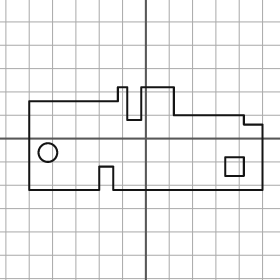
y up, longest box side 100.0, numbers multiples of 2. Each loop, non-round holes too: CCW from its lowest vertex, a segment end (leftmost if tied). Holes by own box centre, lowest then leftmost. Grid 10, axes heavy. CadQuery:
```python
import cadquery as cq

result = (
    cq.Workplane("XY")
    .moveTo(-50.0, -22.0)
    .lineTo(-20.0, -22.0)
    .lineTo(-20.0, -12.0)
    .lineTo(-14.0, -12.0)
    .lineTo(-14.0, -22.0)
    .lineTo(50.0, -22.0)
    .lineTo(50.0, 6.0)
    .lineTo(42.0, 6.0)
    .lineTo(42.0, 10.0)
    .lineTo(12.0, 10.0)
    .lineTo(12.0, 22.0)
    .lineTo(-2.0, 22.0)
    .lineTo(-2.0, 8.0)
    .lineTo(-8.0, 8.0)
    .lineTo(-8.0, 22.0)
    .lineTo(-12.0, 22.0)
    .lineTo(-12.0, 16.0)
    .lineTo(-50.0, 16.0)
    .close()
    .moveTo(34.0, -16.0)
    .lineTo(42.0, -16.0)
    .lineTo(42.0, -8.0)
    .lineTo(34.0, -8.0)
    .close()
    .moveTo(-42.0, -6.0)
    .circle(4.0)
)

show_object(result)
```